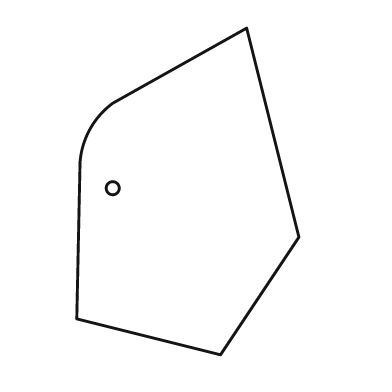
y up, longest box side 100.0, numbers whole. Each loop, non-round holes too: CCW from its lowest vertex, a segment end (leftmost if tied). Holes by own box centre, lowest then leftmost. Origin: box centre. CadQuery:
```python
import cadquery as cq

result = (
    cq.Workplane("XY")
    .moveTo(10.0, -50.0)
    .lineTo(34.0, -14.0)
    .lineTo(18.0, 50.0)
    .lineTo(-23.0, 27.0)
    .threePointArc((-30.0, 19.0), (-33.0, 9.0))
    .lineTo(-34.0, -39.0)
    .close()
    .moveTo(-23.0, 1.0)
    .circle(2.0)
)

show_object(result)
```